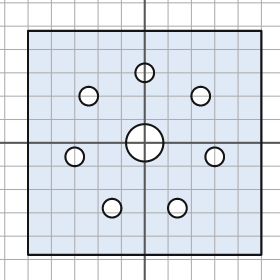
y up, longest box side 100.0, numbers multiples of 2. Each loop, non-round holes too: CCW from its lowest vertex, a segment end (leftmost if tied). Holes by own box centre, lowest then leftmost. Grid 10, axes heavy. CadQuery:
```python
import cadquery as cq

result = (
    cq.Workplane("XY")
    .moveTo(-50.0, -48.0)
    .lineTo(50.0, -48.0)
    .lineTo(50.0, 48.0)
    .lineTo(-50.0, 48.0)
    .close()
    .moveTo(-14.0, -28.0)
    .circle(4.0)
    .moveTo(14.0, -28.0)
    .circle(4.0)
    .moveTo(-30.0, -6.0)
    .circle(4.0)
    .moveTo(30.0, -6.0)
    .circle(4.0)
    .moveTo(0.0, 0.0)
    .circle(8.0)
    .moveTo(-24.0, 20.0)
    .circle(4.0)
    .moveTo(24.0, 20.0)
    .circle(4.0)
    .moveTo(0.0, 30.0)
    .circle(4.0)
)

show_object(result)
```